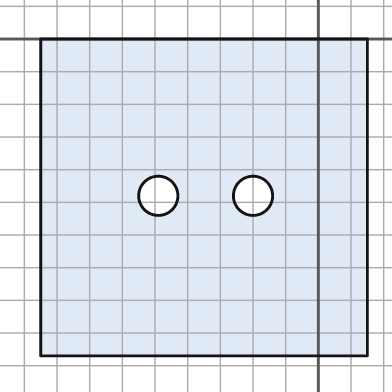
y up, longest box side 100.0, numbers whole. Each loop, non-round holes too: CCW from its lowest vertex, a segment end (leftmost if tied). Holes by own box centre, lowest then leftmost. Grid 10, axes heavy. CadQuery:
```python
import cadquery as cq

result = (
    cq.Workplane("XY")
    .moveTo(-85.0, -97.0)
    .lineTo(15.0, -97.0)
    .lineTo(15.0, 0.0)
    .lineTo(-85.0, 0.0)
    .close()
    .moveTo(-49.0, -48.0)
    .circle(6.0)
    .moveTo(-20.0, -48.0)
    .circle(6.0)
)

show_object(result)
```